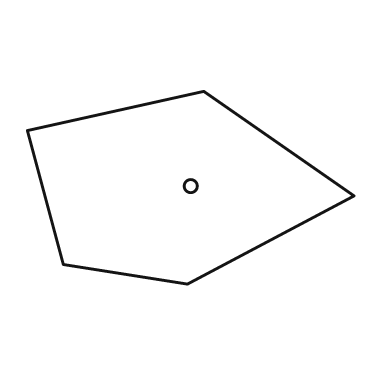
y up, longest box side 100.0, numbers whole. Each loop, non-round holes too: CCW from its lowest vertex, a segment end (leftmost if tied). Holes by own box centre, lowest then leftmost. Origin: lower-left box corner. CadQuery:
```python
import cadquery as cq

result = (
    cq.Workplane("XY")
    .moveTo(49.0, 0.0)
    .lineTo(100.0, 27.0)
    .lineTo(54.0, 59.0)
    .lineTo(0.0, 47.0)
    .lineTo(11.0, 6.0)
    .close()
    .moveTo(50.0, 30.0)
    .circle(2.0)
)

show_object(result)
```